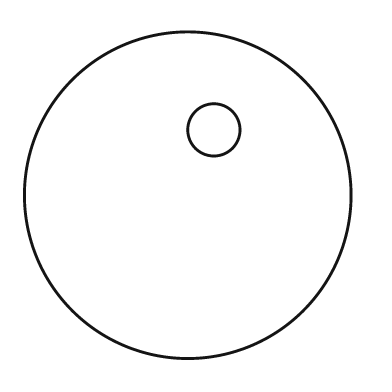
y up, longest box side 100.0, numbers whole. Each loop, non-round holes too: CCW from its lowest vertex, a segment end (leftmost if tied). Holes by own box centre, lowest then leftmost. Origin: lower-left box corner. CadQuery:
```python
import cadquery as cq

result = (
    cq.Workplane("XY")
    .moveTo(50.0, 50.0)
    .circle(50.0)
    .moveTo(58.0, 70.0)
    .circle(8.0)
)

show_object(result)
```